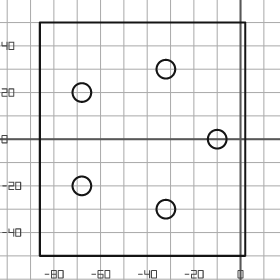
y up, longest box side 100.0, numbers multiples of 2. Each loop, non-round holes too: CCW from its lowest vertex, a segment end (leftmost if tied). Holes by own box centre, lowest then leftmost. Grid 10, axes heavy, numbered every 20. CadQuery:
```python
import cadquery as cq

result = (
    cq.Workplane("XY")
    .moveTo(-86.0, -50.0)
    .lineTo(2.0, -50.0)
    .lineTo(2.0, 50.0)
    .lineTo(-86.0, 50.0)
    .close()
    .moveTo(-32.0, -30.0)
    .circle(4.0)
    .moveTo(-68.0, -20.0)
    .circle(4.0)
    .moveTo(-10.0, 0.0)
    .circle(4.0)
    .moveTo(-68.0, 20.0)
    .circle(4.0)
    .moveTo(-32.0, 30.0)
    .circle(4.0)
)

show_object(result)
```